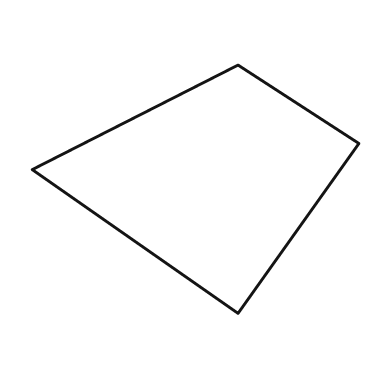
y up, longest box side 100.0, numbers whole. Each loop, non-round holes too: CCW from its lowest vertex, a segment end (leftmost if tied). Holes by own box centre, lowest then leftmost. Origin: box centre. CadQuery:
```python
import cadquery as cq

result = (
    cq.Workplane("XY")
    .moveTo(13.0, -38.0)
    .lineTo(50.0, 14.0)
    .lineTo(13.0, 38.0)
    .lineTo(-50.0, 6.0)
    .close()
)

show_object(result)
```